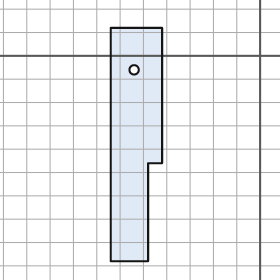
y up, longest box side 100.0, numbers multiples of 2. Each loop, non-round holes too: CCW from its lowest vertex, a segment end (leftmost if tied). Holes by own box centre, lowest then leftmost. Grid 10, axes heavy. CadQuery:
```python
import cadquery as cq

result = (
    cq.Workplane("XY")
    .moveTo(-64.0, -88.0)
    .lineTo(-48.0, -88.0)
    .lineTo(-48.0, -46.0)
    .lineTo(-42.0, -46.0)
    .lineTo(-42.0, 12.0)
    .lineTo(-64.0, 12.0)
    .close()
    .moveTo(-54.0, -6.0)
    .circle(2.0)
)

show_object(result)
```